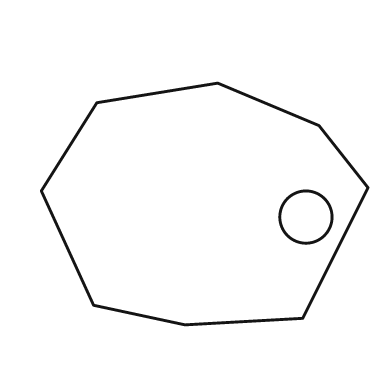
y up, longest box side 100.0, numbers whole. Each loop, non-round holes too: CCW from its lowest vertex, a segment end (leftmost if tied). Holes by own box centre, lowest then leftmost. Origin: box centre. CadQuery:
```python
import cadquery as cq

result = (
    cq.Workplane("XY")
    .moveTo(-6.0, -37.0)
    .lineTo(30.0, -35.0)
    .lineTo(50.0, 5.0)
    .lineTo(35.0, 24.0)
    .lineTo(4.0, 37.0)
    .lineTo(-33.0, 31.0)
    .lineTo(-50.0, 4.0)
    .lineTo(-34.0, -31.0)
    .close()
    .moveTo(31.0, -4.0)
    .circle(8.0)
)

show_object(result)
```